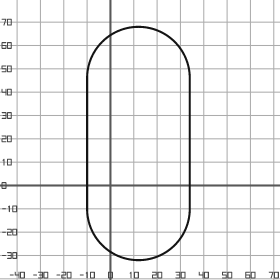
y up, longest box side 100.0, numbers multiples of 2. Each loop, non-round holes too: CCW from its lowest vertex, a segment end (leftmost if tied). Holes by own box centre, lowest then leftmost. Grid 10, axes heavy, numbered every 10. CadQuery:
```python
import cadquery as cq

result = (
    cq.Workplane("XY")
    .moveTo(-10.0, -10.0)
    .threePointArc((12.0, -32.0), (34.0, -10.0))
    .lineTo(34.0, 46.0)
    .threePointArc((12.0, 68.0), (-10.0, 46.0))
    .close()
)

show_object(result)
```